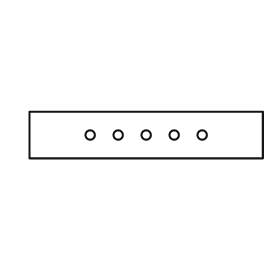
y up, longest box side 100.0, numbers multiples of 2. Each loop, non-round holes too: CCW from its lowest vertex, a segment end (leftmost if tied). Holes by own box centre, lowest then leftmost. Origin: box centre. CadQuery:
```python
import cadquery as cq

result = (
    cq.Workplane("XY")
    .moveTo(-50.0, -10.0)
    .lineTo(50.0, -10.0)
    .lineTo(50.0, 10.0)
    .lineTo(-50.0, 10.0)
    .close()
    .moveTo(-24.0, 0.0)
    .circle(2.0)
    .moveTo(-12.0, 0.0)
    .circle(2.0)
    .moveTo(0.0, 0.0)
    .circle(2.0)
    .moveTo(12.0, 0.0)
    .circle(2.0)
    .moveTo(24.0, 0.0)
    .circle(2.0)
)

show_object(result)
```